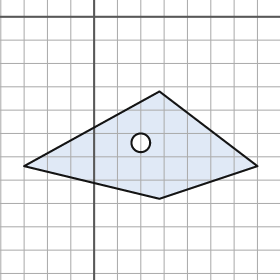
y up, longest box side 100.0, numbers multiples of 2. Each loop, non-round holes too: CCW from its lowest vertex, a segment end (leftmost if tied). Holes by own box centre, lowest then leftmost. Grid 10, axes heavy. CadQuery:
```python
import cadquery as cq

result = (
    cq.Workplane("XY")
    .moveTo(28.0, -78.0)
    .lineTo(70.0, -64.0)
    .lineTo(28.0, -32.0)
    .lineTo(-30.0, -64.0)
    .close()
    .moveTo(20.0, -54.0)
    .circle(4.0)
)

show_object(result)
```